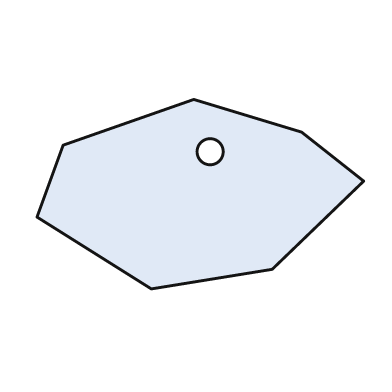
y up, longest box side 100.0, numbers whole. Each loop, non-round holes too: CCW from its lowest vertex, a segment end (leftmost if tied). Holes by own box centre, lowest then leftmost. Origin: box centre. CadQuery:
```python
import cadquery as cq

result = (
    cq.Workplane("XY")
    .moveTo(-15.0, -29.0)
    .lineTo(22.0, -23.0)
    .lineTo(50.0, 4.0)
    .lineTo(31.0, 19.0)
    .lineTo(-2.0, 29.0)
    .lineTo(-42.0, 15.0)
    .lineTo(-50.0, -7.0)
    .close()
    .moveTo(3.0, 13.0)
    .circle(4.0)
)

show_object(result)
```